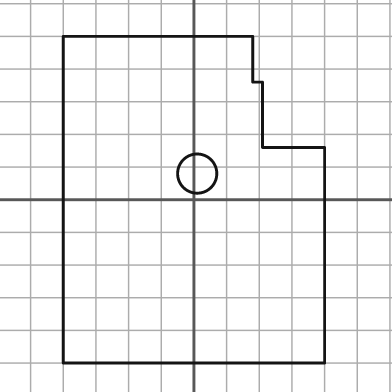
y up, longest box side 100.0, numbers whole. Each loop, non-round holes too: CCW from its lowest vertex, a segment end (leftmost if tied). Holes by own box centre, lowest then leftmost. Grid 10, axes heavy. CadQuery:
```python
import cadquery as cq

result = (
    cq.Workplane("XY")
    .moveTo(-40.0, -50.0)
    .lineTo(40.0, -50.0)
    .lineTo(40.0, 16.0)
    .lineTo(21.0, 16.0)
    .lineTo(21.0, 36.0)
    .lineTo(18.0, 36.0)
    .lineTo(18.0, 50.0)
    .lineTo(-40.0, 50.0)
    .close()
    .moveTo(1.0, 8.0)
    .circle(6.0)
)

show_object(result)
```